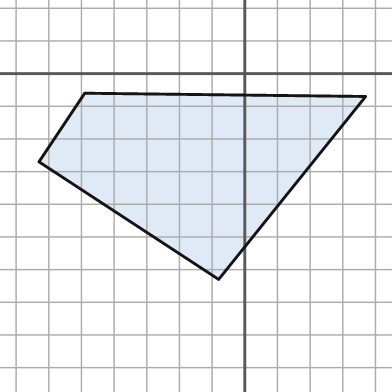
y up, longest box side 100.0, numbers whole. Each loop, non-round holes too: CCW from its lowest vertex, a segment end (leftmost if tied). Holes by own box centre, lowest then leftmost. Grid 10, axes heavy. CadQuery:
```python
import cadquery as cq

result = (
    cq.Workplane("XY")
    .moveTo(-8.0, -63.0)
    .lineTo(37.0, -7.0)
    .lineTo(-49.0, -6.0)
    .lineTo(-63.0, -27.0)
    .close()
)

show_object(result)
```